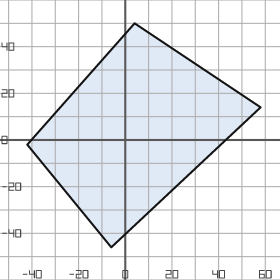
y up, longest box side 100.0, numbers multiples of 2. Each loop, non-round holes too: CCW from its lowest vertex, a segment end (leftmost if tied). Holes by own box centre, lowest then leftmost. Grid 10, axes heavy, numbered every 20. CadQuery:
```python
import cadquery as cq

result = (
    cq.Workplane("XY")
    .moveTo(-6.0, -46.0)
    .lineTo(58.0, 14.0)
    .lineTo(4.0, 50.0)
    .lineTo(-42.0, -2.0)
    .close()
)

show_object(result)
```